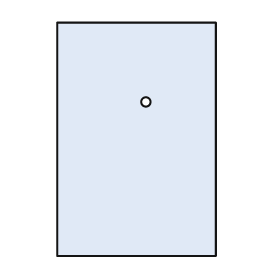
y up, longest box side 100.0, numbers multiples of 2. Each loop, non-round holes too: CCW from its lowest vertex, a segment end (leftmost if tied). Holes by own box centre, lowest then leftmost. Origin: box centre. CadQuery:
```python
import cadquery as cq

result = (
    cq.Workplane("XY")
    .moveTo(-34.0, -50.0)
    .lineTo(34.0, -50.0)
    .lineTo(34.0, 50.0)
    .lineTo(-34.0, 50.0)
    .close()
    .moveTo(4.0, 16.0)
    .circle(2.0)
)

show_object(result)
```